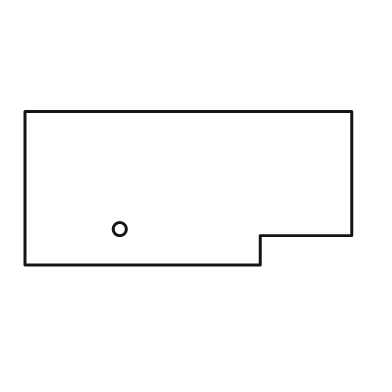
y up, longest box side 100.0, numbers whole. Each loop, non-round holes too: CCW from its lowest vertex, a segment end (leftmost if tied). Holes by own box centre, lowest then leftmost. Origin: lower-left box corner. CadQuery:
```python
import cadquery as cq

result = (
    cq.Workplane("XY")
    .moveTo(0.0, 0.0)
    .lineTo(72.0, 0.0)
    .lineTo(72.0, 9.0)
    .lineTo(100.0, 9.0)
    .lineTo(100.0, 47.0)
    .lineTo(0.0, 47.0)
    .close()
    .moveTo(29.0, 11.0)
    .circle(2.0)
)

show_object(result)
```